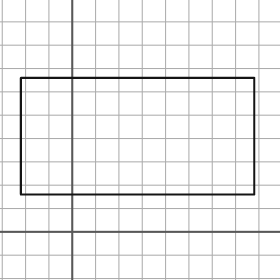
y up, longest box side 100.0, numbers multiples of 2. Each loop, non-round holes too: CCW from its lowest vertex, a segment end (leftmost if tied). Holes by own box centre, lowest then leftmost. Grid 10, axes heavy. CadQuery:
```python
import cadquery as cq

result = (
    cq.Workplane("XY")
    .moveTo(-22.0, 16.0)
    .lineTo(78.0, 16.0)
    .lineTo(78.0, 66.0)
    .lineTo(-22.0, 66.0)
    .close()
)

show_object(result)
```